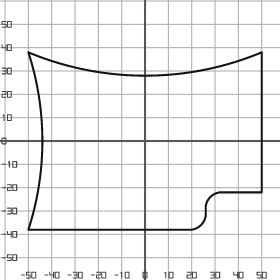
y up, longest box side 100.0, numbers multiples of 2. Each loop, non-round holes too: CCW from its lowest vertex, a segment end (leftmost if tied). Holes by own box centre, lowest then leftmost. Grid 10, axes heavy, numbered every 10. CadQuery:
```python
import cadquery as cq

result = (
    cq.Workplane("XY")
    .moveTo(-50.0, -38.0)
    .lineTo(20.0, -38.0)
    .threePointArc((24.0, -36.0), (26.0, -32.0))
    .lineTo(26.0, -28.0)
    .threePointArc((28.0, -24.0), (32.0, -22.0))
    .lineTo(50.0, -22.0)
    .lineTo(50.0, 38.0)
    .threePointArc((0.0, 28.0), (-50.0, 38.0))
    .threePointArc((-44.0, 0.0), (-50.0, -38.0))
    .close()
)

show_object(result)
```